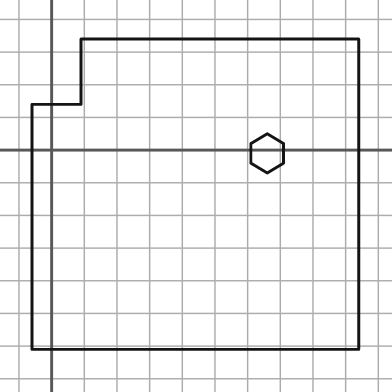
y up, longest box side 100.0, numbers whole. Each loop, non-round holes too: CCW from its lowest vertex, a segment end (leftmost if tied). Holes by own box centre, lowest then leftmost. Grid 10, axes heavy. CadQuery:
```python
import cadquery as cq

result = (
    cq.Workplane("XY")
    .moveTo(-6.0, -61.0)
    .lineTo(94.0, -61.0)
    .lineTo(94.0, 34.0)
    .lineTo(9.0, 34.0)
    .lineTo(9.0, 14.0)
    .lineTo(-6.0, 14.0)
    .close()
    .moveTo(66.0, -7.0)
    .lineTo(71.0, -4.0)
    .lineTo(71.0, 2.0)
    .lineTo(66.0, 5.0)
    .lineTo(61.0, 2.0)
    .lineTo(61.0, -4.0)
    .close()
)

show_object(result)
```